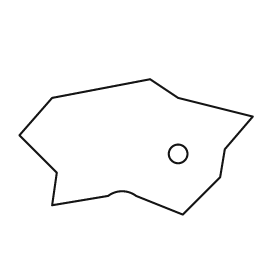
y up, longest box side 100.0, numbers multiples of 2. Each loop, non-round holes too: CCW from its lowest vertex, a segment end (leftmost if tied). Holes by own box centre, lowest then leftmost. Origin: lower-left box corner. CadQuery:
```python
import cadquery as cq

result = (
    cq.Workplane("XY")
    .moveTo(70.0, 0.0)
    .lineTo(86.0, 16.0)
    .lineTo(88.0, 28.0)
    .lineTo(100.0, 42.0)
    .lineTo(68.0, 50.0)
    .lineTo(56.0, 58.0)
    .lineTo(14.0, 50.0)
    .lineTo(0.0, 34.0)
    .lineTo(16.0, 18.0)
    .lineTo(14.0, 4.0)
    .lineTo(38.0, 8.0)
    .threePointArc((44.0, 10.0), (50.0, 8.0))
    .close()
    .moveTo(68.0, 26.0)
    .circle(4.0)
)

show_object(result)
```